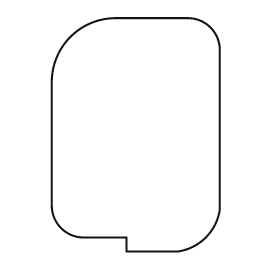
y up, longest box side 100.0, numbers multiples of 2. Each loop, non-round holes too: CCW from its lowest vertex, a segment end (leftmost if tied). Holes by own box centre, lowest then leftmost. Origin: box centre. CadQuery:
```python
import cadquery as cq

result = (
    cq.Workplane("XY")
    .moveTo(-4.0, -50.0)
    .lineTo(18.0, -50.0)
    .threePointArc((30.0, -44.0), (36.0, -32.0))
    .lineTo(36.0, 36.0)
    .threePointArc((32.0, 46.0), (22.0, 50.0))
    .lineTo(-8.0, 50.0)
    .threePointArc((-28.0, 42.0), (-36.0, 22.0))
    .lineTo(-36.0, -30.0)
    .threePointArc((-32.0, -40.0), (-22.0, -44.0))
    .lineTo(-4.0, -44.0)
    .close()
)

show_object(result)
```